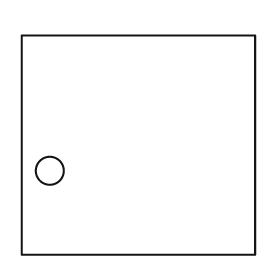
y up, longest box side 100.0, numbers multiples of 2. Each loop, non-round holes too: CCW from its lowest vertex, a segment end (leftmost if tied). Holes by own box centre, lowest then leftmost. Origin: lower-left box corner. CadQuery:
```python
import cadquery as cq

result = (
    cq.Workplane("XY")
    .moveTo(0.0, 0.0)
    .lineTo(100.0, 0.0)
    .lineTo(100.0, 94.0)
    .lineTo(0.0, 94.0)
    .close()
    .moveTo(12.0, 36.0)
    .circle(6.0)
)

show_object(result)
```